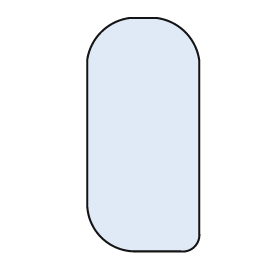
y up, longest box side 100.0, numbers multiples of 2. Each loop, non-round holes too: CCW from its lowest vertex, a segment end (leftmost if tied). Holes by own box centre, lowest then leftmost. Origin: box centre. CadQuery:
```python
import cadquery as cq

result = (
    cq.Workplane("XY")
    .moveTo(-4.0, -50.0)
    .lineTo(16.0, -50.0)
    .threePointArc((22.0, -48.0), (24.0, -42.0))
    .lineTo(24.0, 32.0)
    .threePointArc((18.0, 44.0), (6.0, 50.0))
    .lineTo(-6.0, 50.0)
    .threePointArc((-18.0, 44.0), (-24.0, 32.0))
    .lineTo(-24.0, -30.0)
    .threePointArc((-18.0, -44.0), (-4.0, -50.0))
    .close()
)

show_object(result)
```